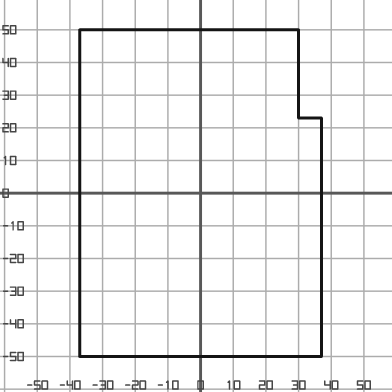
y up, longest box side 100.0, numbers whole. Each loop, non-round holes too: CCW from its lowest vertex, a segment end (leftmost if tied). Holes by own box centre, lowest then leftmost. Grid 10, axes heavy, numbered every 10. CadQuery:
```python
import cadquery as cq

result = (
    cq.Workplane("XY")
    .moveTo(-37.0, -50.0)
    .lineTo(37.0, -50.0)
    .lineTo(37.0, 23.0)
    .lineTo(30.0, 23.0)
    .lineTo(30.0, 50.0)
    .lineTo(-37.0, 50.0)
    .close()
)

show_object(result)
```